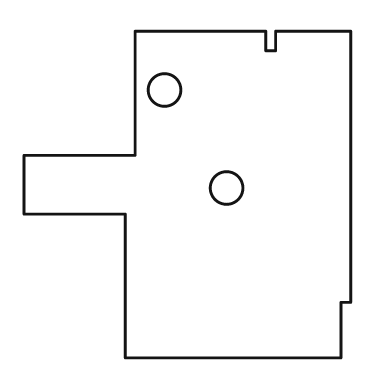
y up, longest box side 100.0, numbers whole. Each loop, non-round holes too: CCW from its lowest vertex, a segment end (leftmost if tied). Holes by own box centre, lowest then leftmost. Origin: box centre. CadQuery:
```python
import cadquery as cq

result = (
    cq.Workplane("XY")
    .moveTo(-19.0, -50.0)
    .lineTo(47.0, -50.0)
    .lineTo(47.0, -33.0)
    .lineTo(50.0, -33.0)
    .lineTo(50.0, 50.0)
    .lineTo(27.0, 50.0)
    .lineTo(27.0, 44.0)
    .lineTo(24.0, 44.0)
    .lineTo(24.0, 50.0)
    .lineTo(-16.0, 50.0)
    .lineTo(-16.0, 12.0)
    .lineTo(-50.0, 12.0)
    .lineTo(-50.0, -6.0)
    .lineTo(-19.0, -6.0)
    .close()
    .moveTo(12.0, 2.0)
    .circle(5.0)
    .moveTo(-7.0, 32.0)
    .circle(5.0)
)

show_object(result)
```